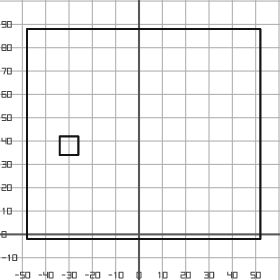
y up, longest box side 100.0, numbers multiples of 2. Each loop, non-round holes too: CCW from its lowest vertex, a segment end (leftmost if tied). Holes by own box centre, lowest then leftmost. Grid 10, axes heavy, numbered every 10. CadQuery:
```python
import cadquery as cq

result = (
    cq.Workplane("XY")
    .moveTo(-48.0, -2.0)
    .lineTo(52.0, -2.0)
    .lineTo(52.0, 88.0)
    .lineTo(-48.0, 88.0)
    .close()
    .moveTo(-34.0, 34.0)
    .lineTo(-26.0, 34.0)
    .lineTo(-26.0, 42.0)
    .lineTo(-34.0, 42.0)
    .close()
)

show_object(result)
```